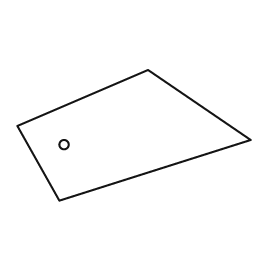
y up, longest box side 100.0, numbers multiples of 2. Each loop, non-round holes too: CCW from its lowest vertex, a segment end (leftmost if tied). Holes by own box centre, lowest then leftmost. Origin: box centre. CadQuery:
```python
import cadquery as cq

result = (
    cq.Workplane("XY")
    .moveTo(-32.0, -28.0)
    .lineTo(50.0, -2.0)
    .lineTo(6.0, 28.0)
    .lineTo(-50.0, 4.0)
    .close()
    .moveTo(-30.0, -4.0)
    .circle(2.0)
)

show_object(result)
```